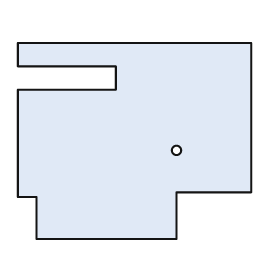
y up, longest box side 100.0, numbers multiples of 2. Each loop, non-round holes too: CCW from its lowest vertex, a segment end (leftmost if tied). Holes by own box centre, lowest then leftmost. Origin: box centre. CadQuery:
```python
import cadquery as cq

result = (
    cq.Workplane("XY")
    .moveTo(-42.0, -42.0)
    .lineTo(18.0, -42.0)
    .lineTo(18.0, -22.0)
    .lineTo(50.0, -22.0)
    .lineTo(50.0, 42.0)
    .lineTo(-50.0, 42.0)
    .lineTo(-50.0, 32.0)
    .lineTo(-8.0, 32.0)
    .lineTo(-8.0, 22.0)
    .lineTo(-50.0, 22.0)
    .lineTo(-50.0, -24.0)
    .lineTo(-42.0, -24.0)
    .close()
    .moveTo(18.0, -4.0)
    .circle(2.0)
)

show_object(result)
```